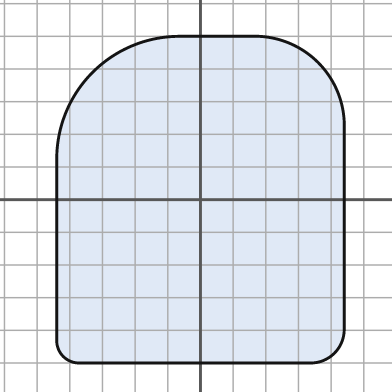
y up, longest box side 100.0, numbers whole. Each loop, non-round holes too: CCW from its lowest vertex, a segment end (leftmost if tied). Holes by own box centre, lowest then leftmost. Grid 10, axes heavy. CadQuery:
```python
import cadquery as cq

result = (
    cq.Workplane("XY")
    .moveTo(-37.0, -50.0)
    .lineTo(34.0, -50.0)
    .threePointArc((41.0, -47.0), (44.0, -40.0))
    .lineTo(44.0, 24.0)
    .threePointArc((36.0, 42.0), (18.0, 50.0))
    .lineTo(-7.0, 50.0)
    .threePointArc((-33.0, 39.0), (-44.0, 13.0))
    .lineTo(-44.0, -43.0)
    .threePointArc((-42.0, -48.0), (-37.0, -50.0))
    .close()
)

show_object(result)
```